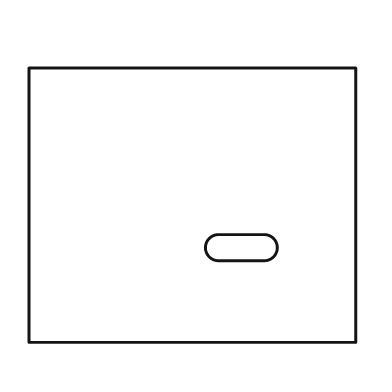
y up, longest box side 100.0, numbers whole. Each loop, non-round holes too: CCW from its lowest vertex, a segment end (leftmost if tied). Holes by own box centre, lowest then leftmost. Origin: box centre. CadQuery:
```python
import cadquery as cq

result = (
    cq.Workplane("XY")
    .moveTo(-50.0, -42.0)
    .lineTo(50.0, -42.0)
    .lineTo(50.0, 42.0)
    .lineTo(-50.0, 42.0)
    .close()
    .moveTo(8.0, -17.0)
    .lineTo(22.0, -17.0)
    .threePointArc((26.0, -13.0), (22.0, -9.0))
    .lineTo(8.0, -9.0)
    .threePointArc((4.0, -13.0), (8.0, -17.0))
    .close()
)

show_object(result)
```